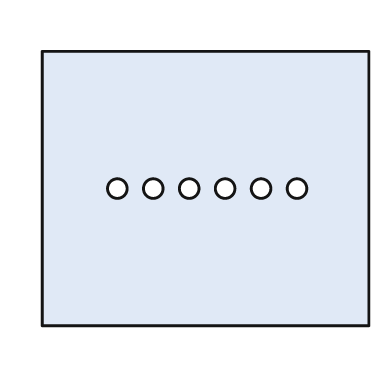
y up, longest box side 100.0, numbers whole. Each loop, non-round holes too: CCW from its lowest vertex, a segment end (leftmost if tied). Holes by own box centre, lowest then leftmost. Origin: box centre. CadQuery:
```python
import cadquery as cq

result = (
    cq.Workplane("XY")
    .moveTo(-50.0, -42.0)
    .lineTo(50.0, -42.0)
    .lineTo(50.0, 42.0)
    .lineTo(-50.0, 42.0)
    .close()
    .moveTo(-27.0, 0.0)
    .circle(3.0)
    .moveTo(-16.0, 0.0)
    .circle(3.0)
    .moveTo(-5.0, 0.0)
    .circle(3.0)
    .moveTo(6.0, 0.0)
    .circle(3.0)
    .moveTo(17.0, 0.0)
    .circle(3.0)
    .moveTo(28.0, 0.0)
    .circle(3.0)
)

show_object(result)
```